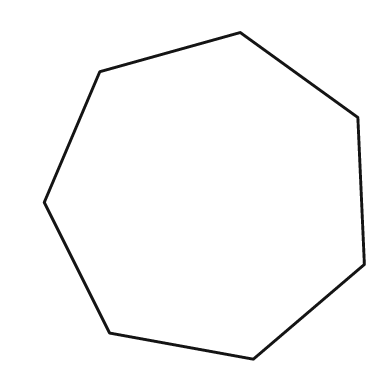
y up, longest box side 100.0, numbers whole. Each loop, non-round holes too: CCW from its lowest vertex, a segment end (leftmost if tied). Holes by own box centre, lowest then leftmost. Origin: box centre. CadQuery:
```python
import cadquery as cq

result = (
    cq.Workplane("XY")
    .moveTo(15.0, -50.0)
    .lineTo(49.0, -21.0)
    .lineTo(47.0, 24.0)
    .lineTo(11.0, 50.0)
    .lineTo(-32.0, 38.0)
    .lineTo(-49.0, -2.0)
    .lineTo(-29.0, -42.0)
    .close()
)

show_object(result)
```